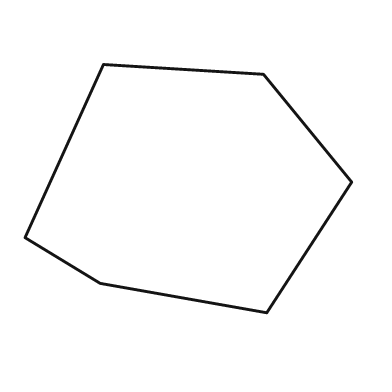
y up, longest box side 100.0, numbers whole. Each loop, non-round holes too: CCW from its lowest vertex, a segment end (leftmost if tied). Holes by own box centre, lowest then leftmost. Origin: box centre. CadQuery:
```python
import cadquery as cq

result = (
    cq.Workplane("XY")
    .moveTo(24.0, -38.0)
    .lineTo(50.0, 2.0)
    .lineTo(23.0, 35.0)
    .lineTo(-26.0, 38.0)
    .lineTo(-50.0, -15.0)
    .lineTo(-27.0, -29.0)
    .close()
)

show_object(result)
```